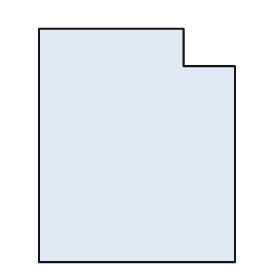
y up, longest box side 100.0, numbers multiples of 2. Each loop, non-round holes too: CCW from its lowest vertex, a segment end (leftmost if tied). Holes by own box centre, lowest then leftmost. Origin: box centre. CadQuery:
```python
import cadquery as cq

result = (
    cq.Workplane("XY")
    .moveTo(-42.0, -50.0)
    .lineTo(42.0, -50.0)
    .lineTo(42.0, 34.0)
    .lineTo(20.0, 34.0)
    .lineTo(20.0, 50.0)
    .lineTo(-42.0, 50.0)
    .close()
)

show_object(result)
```